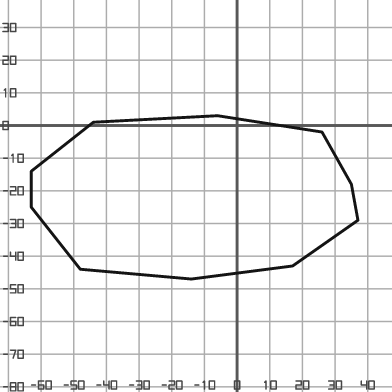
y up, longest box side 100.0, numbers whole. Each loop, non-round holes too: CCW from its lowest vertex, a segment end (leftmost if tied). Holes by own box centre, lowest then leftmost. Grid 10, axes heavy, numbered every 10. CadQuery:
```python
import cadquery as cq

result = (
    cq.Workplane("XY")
    .moveTo(-14.0, -47.0)
    .lineTo(17.0, -43.0)
    .lineTo(37.0, -29.0)
    .lineTo(35.0, -18.0)
    .lineTo(26.0, -2.0)
    .lineTo(-6.0, 3.0)
    .lineTo(-44.0, 1.0)
    .lineTo(-63.0, -14.0)
    .lineTo(-63.0, -25.0)
    .lineTo(-48.0, -44.0)
    .close()
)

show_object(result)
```